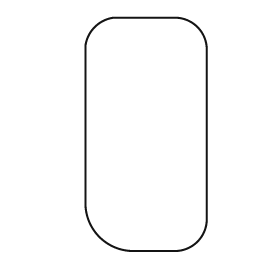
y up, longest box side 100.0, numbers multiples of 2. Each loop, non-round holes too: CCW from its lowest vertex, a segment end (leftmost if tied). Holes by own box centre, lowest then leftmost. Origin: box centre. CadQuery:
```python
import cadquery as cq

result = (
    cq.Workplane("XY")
    .moveTo(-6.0, -50.0)
    .lineTo(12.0, -50.0)
    .threePointArc((22.0, -46.0), (26.0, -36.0))
    .lineTo(26.0, 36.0)
    .threePointArc((22.0, 46.0), (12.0, 50.0))
    .lineTo(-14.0, 50.0)
    .threePointArc((-22.0, 46.0), (-26.0, 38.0))
    .lineTo(-26.0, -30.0)
    .threePointArc((-20.0, -44.0), (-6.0, -50.0))
    .close()
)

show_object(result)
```